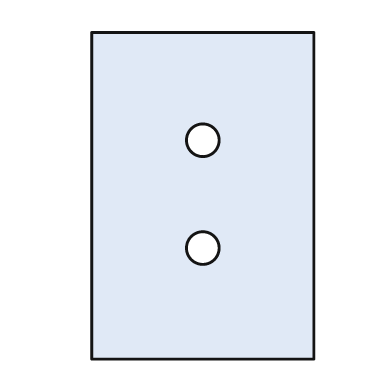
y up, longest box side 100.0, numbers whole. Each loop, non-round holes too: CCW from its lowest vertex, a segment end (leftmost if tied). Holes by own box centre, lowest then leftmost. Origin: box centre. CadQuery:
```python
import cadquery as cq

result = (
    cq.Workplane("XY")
    .moveTo(-34.0, -50.0)
    .lineTo(34.0, -50.0)
    .lineTo(34.0, 50.0)
    .lineTo(-34.0, 50.0)
    .close()
    .moveTo(0.0, -16.0)
    .circle(5.0)
    .moveTo(0.0, 17.0)
    .circle(5.0)
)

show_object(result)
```